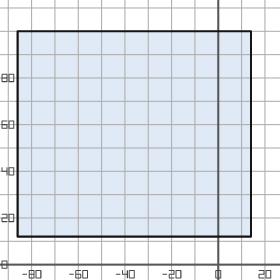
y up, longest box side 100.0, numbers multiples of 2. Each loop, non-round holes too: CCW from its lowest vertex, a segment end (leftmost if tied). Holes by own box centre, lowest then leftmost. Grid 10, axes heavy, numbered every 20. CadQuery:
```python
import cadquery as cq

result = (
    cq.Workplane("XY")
    .moveTo(-86.0, 12.0)
    .lineTo(14.0, 12.0)
    .lineTo(14.0, 100.0)
    .lineTo(-86.0, 100.0)
    .close()
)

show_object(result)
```